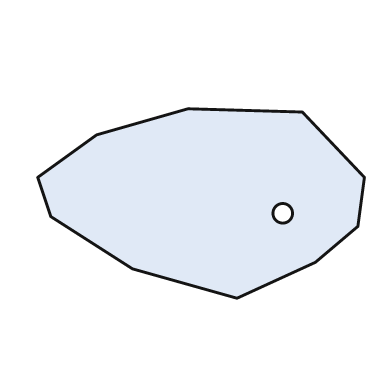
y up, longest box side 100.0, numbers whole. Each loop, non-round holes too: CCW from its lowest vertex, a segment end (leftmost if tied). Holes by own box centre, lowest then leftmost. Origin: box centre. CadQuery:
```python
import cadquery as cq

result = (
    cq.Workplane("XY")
    .moveTo(11.0, -29.0)
    .lineTo(35.0, -18.0)
    .lineTo(48.0, -7.0)
    .lineTo(50.0, 8.0)
    .lineTo(31.0, 28.0)
    .lineTo(-4.0, 29.0)
    .lineTo(-32.0, 21.0)
    .lineTo(-50.0, 8.0)
    .lineTo(-46.0, -4.0)
    .lineTo(-21.0, -20.0)
    .close()
    .moveTo(25.0, -3.0)
    .circle(3.0)
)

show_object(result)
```